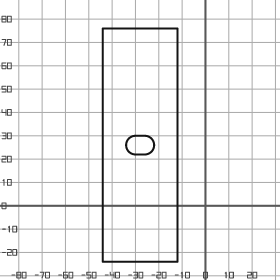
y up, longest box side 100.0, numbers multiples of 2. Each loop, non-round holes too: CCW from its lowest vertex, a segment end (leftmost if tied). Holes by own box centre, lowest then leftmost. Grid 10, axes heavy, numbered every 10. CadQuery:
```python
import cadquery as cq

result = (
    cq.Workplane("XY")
    .moveTo(-44.0, -24.0)
    .lineTo(-12.0, -24.0)
    .lineTo(-12.0, 76.0)
    .lineTo(-44.0, 76.0)
    .close()
    .moveTo(-30.0, 22.0)
    .lineTo(-26.0, 22.0)
    .threePointArc((-22.0, 26.0), (-26.0, 30.0))
    .lineTo(-30.0, 30.0)
    .threePointArc((-34.0, 26.0), (-30.0, 22.0))
    .close()
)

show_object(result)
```